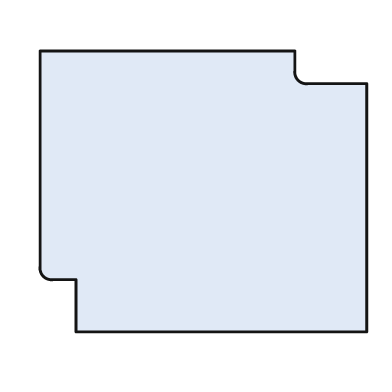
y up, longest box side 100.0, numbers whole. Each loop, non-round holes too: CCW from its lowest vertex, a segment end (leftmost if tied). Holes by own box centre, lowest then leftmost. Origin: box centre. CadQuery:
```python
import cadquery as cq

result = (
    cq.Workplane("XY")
    .moveTo(-39.0, -43.0)
    .lineTo(50.0, -43.0)
    .lineTo(50.0, 33.0)
    .lineTo(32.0, 33.0)
    .threePointArc((29.0, 34.0), (28.0, 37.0))
    .lineTo(28.0, 43.0)
    .lineTo(-50.0, 43.0)
    .lineTo(-50.0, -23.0)
    .threePointArc((-49.0, -26.0), (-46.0, -27.0))
    .lineTo(-39.0, -27.0)
    .close()
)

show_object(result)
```